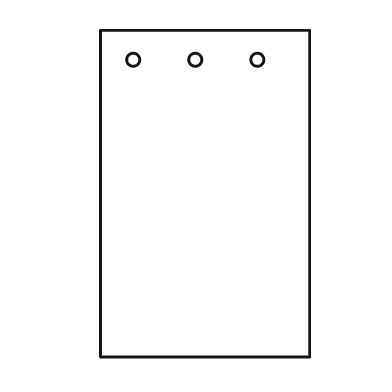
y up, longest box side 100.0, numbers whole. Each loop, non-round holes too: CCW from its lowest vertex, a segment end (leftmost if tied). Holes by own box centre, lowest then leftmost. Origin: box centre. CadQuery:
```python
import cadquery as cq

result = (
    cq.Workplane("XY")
    .moveTo(-32.0, -50.0)
    .lineTo(32.0, -50.0)
    .lineTo(32.0, 50.0)
    .lineTo(-32.0, 50.0)
    .close()
    .moveTo(-22.0, 41.0)
    .circle(2.0)
    .moveTo(-3.0, 41.0)
    .circle(2.0)
    .moveTo(16.0, 41.0)
    .circle(2.0)
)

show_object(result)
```